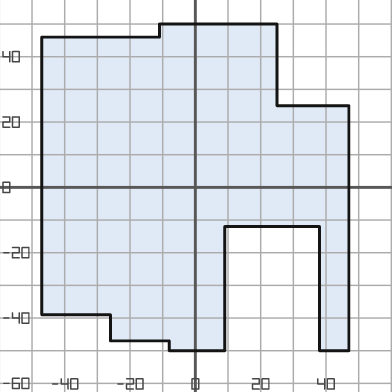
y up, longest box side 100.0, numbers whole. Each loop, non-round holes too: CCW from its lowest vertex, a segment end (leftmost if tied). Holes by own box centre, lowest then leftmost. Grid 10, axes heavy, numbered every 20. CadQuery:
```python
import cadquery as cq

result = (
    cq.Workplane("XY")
    .moveTo(-8.0, -50.0)
    .lineTo(9.0, -50.0)
    .lineTo(9.0, -12.0)
    .lineTo(38.0, -12.0)
    .lineTo(38.0, -50.0)
    .lineTo(47.0, -50.0)
    .lineTo(47.0, 25.0)
    .lineTo(25.0, 25.0)
    .lineTo(25.0, 50.0)
    .lineTo(-11.0, 50.0)
    .lineTo(-11.0, 46.0)
    .lineTo(-47.0, 46.0)
    .lineTo(-47.0, -39.0)
    .lineTo(-26.0, -39.0)
    .lineTo(-26.0, -47.0)
    .lineTo(-8.0, -47.0)
    .close()
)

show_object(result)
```